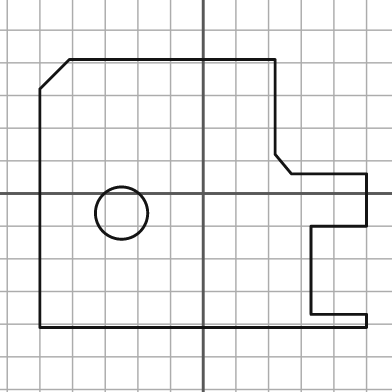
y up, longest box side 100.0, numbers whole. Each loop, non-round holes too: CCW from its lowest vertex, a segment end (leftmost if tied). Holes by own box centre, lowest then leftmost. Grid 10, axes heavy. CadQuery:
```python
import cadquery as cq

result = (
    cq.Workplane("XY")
    .moveTo(-50.0, -41.0)
    .lineTo(50.0, -41.0)
    .lineTo(50.0, -37.0)
    .lineTo(33.0, -37.0)
    .lineTo(33.0, -10.0)
    .lineTo(50.0, -10.0)
    .lineTo(50.0, 6.0)
    .lineTo(27.0, 6.0)
    .lineTo(22.0, 12.0)
    .lineTo(22.0, 41.0)
    .lineTo(-41.0, 41.0)
    .lineTo(-50.0, 32.0)
    .close()
    .moveTo(-25.0, -6.0)
    .circle(8.0)
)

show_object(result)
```